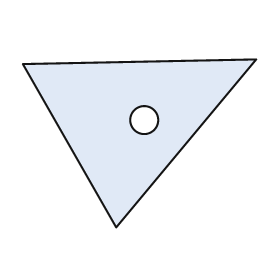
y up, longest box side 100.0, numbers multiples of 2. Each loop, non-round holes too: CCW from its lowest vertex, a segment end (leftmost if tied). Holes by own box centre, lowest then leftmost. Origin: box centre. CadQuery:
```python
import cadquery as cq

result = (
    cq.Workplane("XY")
    .moveTo(-10.0, -36.0)
    .lineTo(50.0, 36.0)
    .lineTo(-50.0, 34.0)
    .close()
    .moveTo(2.0, 10.0)
    .circle(6.0)
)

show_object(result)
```